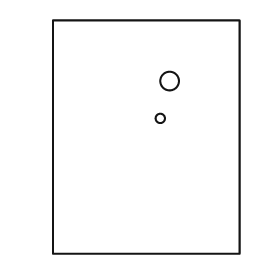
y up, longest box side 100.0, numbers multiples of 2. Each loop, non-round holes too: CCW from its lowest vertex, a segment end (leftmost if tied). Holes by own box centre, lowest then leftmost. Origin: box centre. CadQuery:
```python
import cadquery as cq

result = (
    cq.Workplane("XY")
    .moveTo(-40.0, -50.0)
    .lineTo(40.0, -50.0)
    .lineTo(40.0, 50.0)
    .lineTo(-40.0, 50.0)
    .close()
    .moveTo(6.0, 8.0)
    .circle(2.0)
    .moveTo(10.0, 24.0)
    .circle(4.0)
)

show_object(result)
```